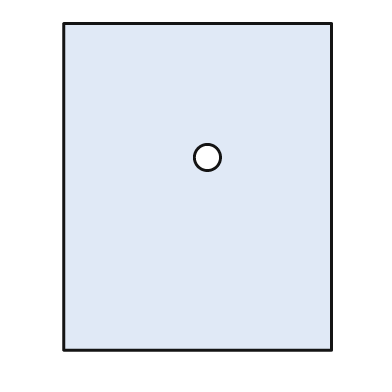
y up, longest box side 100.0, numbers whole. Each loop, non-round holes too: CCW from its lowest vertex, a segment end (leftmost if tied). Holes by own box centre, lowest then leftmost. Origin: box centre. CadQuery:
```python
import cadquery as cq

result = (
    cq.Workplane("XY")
    .moveTo(-41.0, -50.0)
    .lineTo(41.0, -50.0)
    .lineTo(41.0, 50.0)
    .lineTo(-41.0, 50.0)
    .close()
    .moveTo(3.0, 9.0)
    .circle(4.0)
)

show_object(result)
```